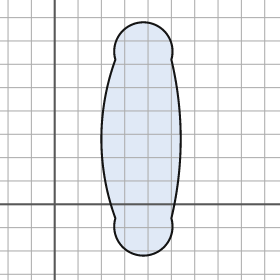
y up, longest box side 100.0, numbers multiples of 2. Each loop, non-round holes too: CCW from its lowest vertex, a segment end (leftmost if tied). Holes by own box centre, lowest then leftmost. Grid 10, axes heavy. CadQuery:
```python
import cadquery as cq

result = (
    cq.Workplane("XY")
    .moveTo(26.0, -6.0)
    .threePointArc((38.0, -22.0), (50.0, -6.0))
    .threePointArc((54.0, 28.0), (50.0, 62.0))
    .threePointArc((38.0, 78.0), (26.0, 62.0))
    .threePointArc((20.0, 28.0), (26.0, -6.0))
    .close()
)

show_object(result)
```